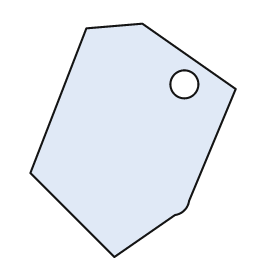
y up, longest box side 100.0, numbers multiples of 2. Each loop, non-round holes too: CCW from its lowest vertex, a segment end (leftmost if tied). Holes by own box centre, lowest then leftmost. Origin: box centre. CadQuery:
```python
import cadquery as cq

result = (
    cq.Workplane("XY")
    .moveTo(-8.0, -50.0)
    .lineTo(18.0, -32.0)
    .threePointArc((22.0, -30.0), (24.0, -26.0))
    .lineTo(44.0, 22.0)
    .lineTo(4.0, 50.0)
    .lineTo(-20.0, 48.0)
    .lineTo(-44.0, -14.0)
    .close()
    .moveTo(22.0, 24.0)
    .circle(6.0)
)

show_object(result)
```